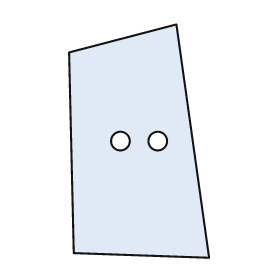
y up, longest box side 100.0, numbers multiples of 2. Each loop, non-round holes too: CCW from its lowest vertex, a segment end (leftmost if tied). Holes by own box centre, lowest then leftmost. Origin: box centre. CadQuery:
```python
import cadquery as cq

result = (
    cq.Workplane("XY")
    .moveTo(30.0, -50.0)
    .lineTo(16.0, 50.0)
    .lineTo(-30.0, 38.0)
    .lineTo(-28.0, -48.0)
    .close()
    .moveTo(-8.0, 0.0)
    .circle(4.0)
    .moveTo(8.0, 0.0)
    .circle(4.0)
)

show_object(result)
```